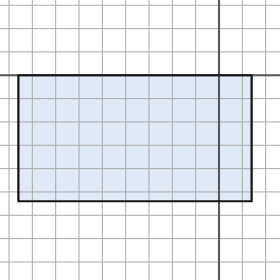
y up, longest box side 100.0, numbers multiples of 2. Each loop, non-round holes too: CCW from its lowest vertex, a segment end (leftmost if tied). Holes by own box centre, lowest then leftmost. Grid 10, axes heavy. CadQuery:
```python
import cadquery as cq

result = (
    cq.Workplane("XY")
    .moveTo(-86.0, -54.0)
    .lineTo(14.0, -54.0)
    .lineTo(14.0, 0.0)
    .lineTo(-86.0, 0.0)
    .close()
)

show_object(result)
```